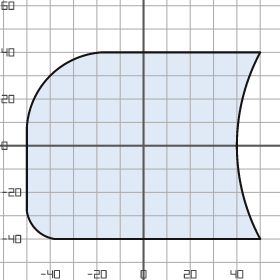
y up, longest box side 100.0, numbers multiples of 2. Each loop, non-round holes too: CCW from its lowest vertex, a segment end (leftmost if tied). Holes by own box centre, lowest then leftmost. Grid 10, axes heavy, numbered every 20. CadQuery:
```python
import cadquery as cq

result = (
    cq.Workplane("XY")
    .moveTo(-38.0, -40.0)
    .lineTo(50.0, -40.0)
    .threePointArc((40.0, 0.0), (50.0, 40.0))
    .lineTo(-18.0, 40.0)
    .threePointArc((-40.0, 30.0), (-50.0, 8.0))
    .lineTo(-50.0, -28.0)
    .threePointArc((-46.0, -36.0), (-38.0, -40.0))
    .close()
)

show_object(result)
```